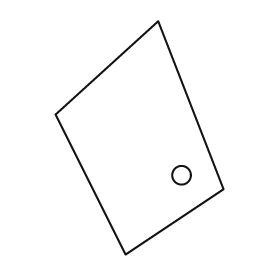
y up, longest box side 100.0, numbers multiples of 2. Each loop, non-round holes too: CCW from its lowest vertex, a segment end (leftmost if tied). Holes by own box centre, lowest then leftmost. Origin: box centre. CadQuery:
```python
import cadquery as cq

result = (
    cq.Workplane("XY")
    .moveTo(-6.0, -50.0)
    .lineTo(36.0, -22.0)
    .lineTo(8.0, 50.0)
    .lineTo(-36.0, 10.0)
    .close()
    .moveTo(18.0, -16.0)
    .circle(4.0)
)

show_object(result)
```